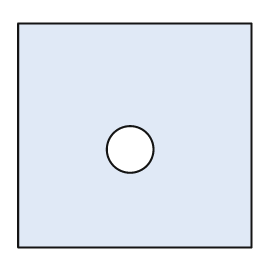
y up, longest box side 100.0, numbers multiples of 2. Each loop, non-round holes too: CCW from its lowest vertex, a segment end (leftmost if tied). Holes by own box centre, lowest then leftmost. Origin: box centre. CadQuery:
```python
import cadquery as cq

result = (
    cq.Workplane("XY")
    .moveTo(-50.0, -48.0)
    .lineTo(50.0, -48.0)
    .lineTo(50.0, 48.0)
    .lineTo(-50.0, 48.0)
    .close()
    .moveTo(-2.0, -6.0)
    .circle(10.0)
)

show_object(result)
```